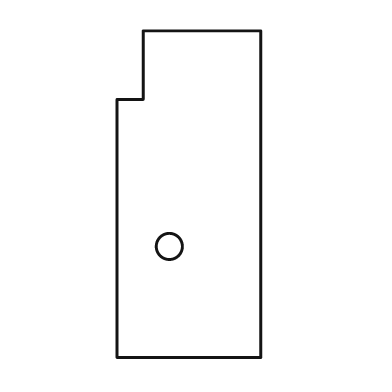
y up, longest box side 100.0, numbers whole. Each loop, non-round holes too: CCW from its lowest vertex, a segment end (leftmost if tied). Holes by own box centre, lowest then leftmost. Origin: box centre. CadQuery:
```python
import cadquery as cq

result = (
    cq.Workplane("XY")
    .moveTo(-22.0, -50.0)
    .lineTo(22.0, -50.0)
    .lineTo(22.0, 50.0)
    .lineTo(-14.0, 50.0)
    .lineTo(-14.0, 29.0)
    .lineTo(-22.0, 29.0)
    .close()
    .moveTo(-6.0, -16.0)
    .circle(4.0)
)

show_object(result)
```